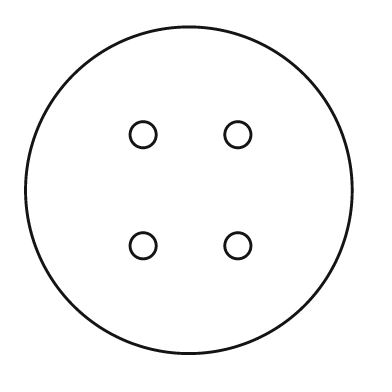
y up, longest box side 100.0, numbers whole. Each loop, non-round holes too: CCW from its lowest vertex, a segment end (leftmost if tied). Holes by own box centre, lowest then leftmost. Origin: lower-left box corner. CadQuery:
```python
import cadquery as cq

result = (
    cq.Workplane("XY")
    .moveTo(50.0, 50.0)
    .circle(50.0)
    .moveTo(36.0, 33.0)
    .circle(4.0)
    .moveTo(65.0, 33.0)
    .circle(4.0)
    .moveTo(36.0, 67.0)
    .circle(4.0)
    .moveTo(65.0, 67.0)
    .circle(4.0)
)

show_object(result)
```